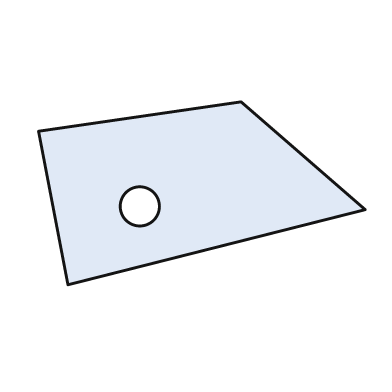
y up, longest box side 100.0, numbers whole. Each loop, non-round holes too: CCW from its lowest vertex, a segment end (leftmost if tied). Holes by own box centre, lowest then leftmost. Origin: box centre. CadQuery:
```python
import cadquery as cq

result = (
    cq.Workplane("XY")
    .moveTo(-41.0, -28.0)
    .lineTo(50.0, -5.0)
    .lineTo(12.0, 28.0)
    .lineTo(-50.0, 19.0)
    .close()
    .moveTo(-19.0, -4.0)
    .circle(6.0)
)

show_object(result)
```